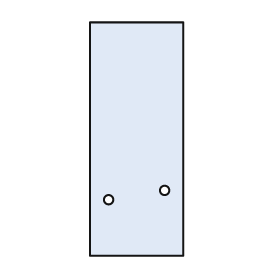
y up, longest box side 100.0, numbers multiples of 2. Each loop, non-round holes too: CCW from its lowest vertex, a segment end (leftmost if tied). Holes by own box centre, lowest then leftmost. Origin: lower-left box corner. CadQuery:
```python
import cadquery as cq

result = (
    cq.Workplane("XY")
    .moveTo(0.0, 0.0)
    .lineTo(40.0, 0.0)
    .lineTo(40.0, 100.0)
    .lineTo(0.0, 100.0)
    .close()
    .moveTo(8.0, 24.0)
    .circle(2.0)
    .moveTo(32.0, 28.0)
    .circle(2.0)
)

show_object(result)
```